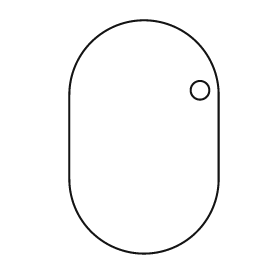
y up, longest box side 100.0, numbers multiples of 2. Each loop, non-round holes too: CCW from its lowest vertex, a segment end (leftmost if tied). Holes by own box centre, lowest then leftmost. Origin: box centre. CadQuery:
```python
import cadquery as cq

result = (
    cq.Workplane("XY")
    .moveTo(-32.0, -18.0)
    .threePointArc((0.0, -50.0), (32.0, -18.0))
    .lineTo(32.0, 18.0)
    .threePointArc((0.0, 50.0), (-32.0, 18.0))
    .close()
    .moveTo(24.0, 20.0)
    .circle(4.0)
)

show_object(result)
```